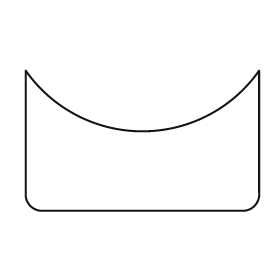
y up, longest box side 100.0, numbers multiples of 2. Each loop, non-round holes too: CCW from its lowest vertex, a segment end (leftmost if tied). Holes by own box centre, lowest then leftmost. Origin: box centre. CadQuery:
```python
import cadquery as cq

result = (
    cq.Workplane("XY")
    .moveTo(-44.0, -30.0)
    .lineTo(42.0, -30.0)
    .threePointArc((48.0, -28.0), (50.0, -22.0))
    .lineTo(50.0, 30.0)
    .threePointArc((0.0, 4.0), (-50.0, 30.0))
    .lineTo(-50.0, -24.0)
    .threePointArc((-48.0, -28.0), (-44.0, -30.0))
    .close()
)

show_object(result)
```